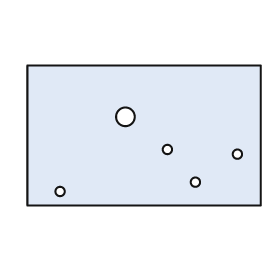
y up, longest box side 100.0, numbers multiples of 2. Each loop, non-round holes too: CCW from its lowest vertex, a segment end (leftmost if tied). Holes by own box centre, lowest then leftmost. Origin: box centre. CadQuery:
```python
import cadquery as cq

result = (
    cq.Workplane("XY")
    .moveTo(-50.0, -30.0)
    .lineTo(50.0, -30.0)
    .lineTo(50.0, 30.0)
    .lineTo(-50.0, 30.0)
    .close()
    .moveTo(-36.0, -24.0)
    .circle(2.0)
    .moveTo(22.0, -20.0)
    .circle(2.0)
    .moveTo(40.0, -8.0)
    .circle(2.0)
    .moveTo(10.0, -6.0)
    .circle(2.0)
    .moveTo(-8.0, 8.0)
    .circle(4.0)
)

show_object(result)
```